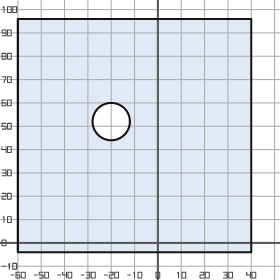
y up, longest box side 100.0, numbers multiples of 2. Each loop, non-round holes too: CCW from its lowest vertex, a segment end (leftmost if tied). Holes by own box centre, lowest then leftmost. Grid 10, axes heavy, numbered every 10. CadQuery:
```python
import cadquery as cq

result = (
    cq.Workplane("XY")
    .moveTo(-60.0, -4.0)
    .lineTo(40.0, -4.0)
    .lineTo(40.0, 96.0)
    .lineTo(-60.0, 96.0)
    .close()
    .moveTo(-20.0, 52.0)
    .circle(8.0)
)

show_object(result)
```